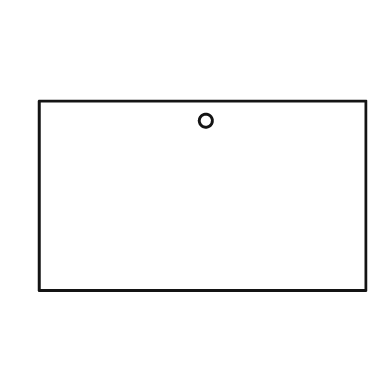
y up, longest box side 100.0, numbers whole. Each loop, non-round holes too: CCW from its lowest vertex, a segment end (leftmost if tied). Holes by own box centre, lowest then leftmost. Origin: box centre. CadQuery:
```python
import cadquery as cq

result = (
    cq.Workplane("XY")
    .moveTo(-50.0, -29.0)
    .lineTo(50.0, -29.0)
    .lineTo(50.0, 29.0)
    .lineTo(-50.0, 29.0)
    .close()
    .moveTo(1.0, 23.0)
    .circle(2.0)
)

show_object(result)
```